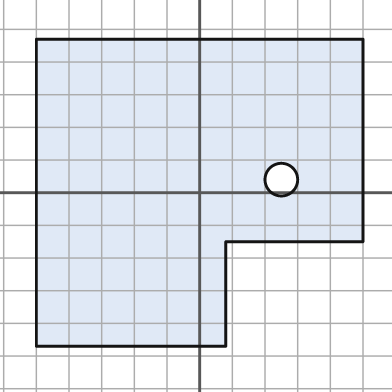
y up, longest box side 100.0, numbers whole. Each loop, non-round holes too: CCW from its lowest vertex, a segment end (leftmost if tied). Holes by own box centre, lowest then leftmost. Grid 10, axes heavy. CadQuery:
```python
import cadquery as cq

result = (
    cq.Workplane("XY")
    .moveTo(-50.0, -47.0)
    .lineTo(8.0, -47.0)
    .lineTo(8.0, -15.0)
    .lineTo(50.0, -15.0)
    .lineTo(50.0, 47.0)
    .lineTo(-50.0, 47.0)
    .close()
    .moveTo(25.0, 4.0)
    .circle(5.0)
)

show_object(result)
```